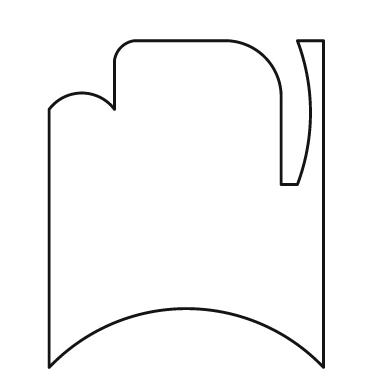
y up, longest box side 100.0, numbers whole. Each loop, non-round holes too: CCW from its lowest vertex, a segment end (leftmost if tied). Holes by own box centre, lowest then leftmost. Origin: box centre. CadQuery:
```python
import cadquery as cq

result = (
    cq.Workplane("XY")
    .moveTo(-42.0, -50.0)
    .threePointArc((0.0, -32.0), (42.0, -50.0))
    .lineTo(42.0, 50.0)
    .lineTo(34.0, 50.0)
    .threePointArc((38.0, 28.0), (34.0, 6.0))
    .lineTo(29.0, 6.0)
    .lineTo(29.0, 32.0)
    .threePointArc((24.0, 45.0), (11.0, 50.0))
    .lineTo(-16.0, 50.0)
    .threePointArc((-20.0, 48.0), (-22.0, 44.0))
    .lineTo(-22.0, 29.0)
    .threePointArc((-32.0, 34.0), (-42.0, 29.0))
    .close()
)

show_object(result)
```